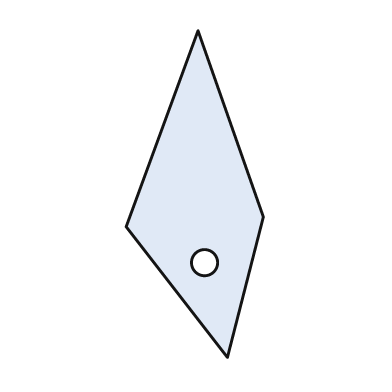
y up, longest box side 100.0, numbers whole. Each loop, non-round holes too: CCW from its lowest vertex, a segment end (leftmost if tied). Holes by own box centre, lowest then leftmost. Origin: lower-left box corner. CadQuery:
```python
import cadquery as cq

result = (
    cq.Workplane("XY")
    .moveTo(31.0, 0.0)
    .lineTo(42.0, 43.0)
    .lineTo(22.0, 100.0)
    .lineTo(0.0, 40.0)
    .close()
    .moveTo(24.0, 29.0)
    .circle(4.0)
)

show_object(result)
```